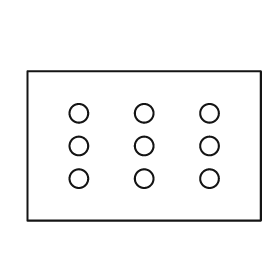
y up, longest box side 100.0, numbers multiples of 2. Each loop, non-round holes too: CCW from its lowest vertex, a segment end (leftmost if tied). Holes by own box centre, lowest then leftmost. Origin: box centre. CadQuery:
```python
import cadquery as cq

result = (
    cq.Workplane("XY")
    .moveTo(-50.0, -32.0)
    .lineTo(50.0, -32.0)
    .lineTo(50.0, 32.0)
    .lineTo(-50.0, 32.0)
    .close()
    .moveTo(-28.0, -14.0)
    .circle(4.0)
    .moveTo(0.0, -14.0)
    .circle(4.0)
    .moveTo(28.0, -14.0)
    .circle(4.0)
    .moveTo(-28.0, 0.0)
    .circle(4.0)
    .moveTo(0.0, 0.0)
    .circle(4.0)
    .moveTo(28.0, 0.0)
    .circle(4.0)
    .moveTo(-28.0, 14.0)
    .circle(4.0)
    .moveTo(0.0, 14.0)
    .circle(4.0)
    .moveTo(28.0, 14.0)
    .circle(4.0)
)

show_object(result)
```